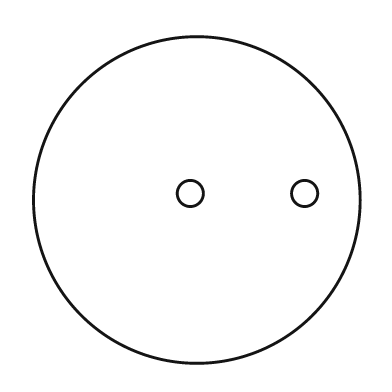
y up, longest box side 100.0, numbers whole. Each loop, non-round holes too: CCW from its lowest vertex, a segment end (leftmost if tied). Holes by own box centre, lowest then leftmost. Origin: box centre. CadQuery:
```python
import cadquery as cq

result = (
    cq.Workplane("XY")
    .moveTo(0.0, 0.0)
    .circle(50.0)
    .moveTo(-2.0, 2.0)
    .circle(4.0)
    .moveTo(33.0, 2.0)
    .circle(4.0)
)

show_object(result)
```